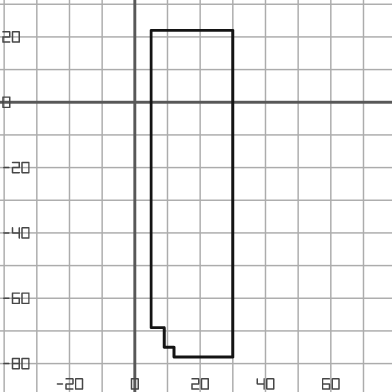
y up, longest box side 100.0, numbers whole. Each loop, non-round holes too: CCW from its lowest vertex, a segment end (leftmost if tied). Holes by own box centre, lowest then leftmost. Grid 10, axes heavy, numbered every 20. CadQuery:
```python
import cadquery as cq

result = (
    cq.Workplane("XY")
    .moveTo(12.0, -78.0)
    .lineTo(30.0, -78.0)
    .lineTo(30.0, 22.0)
    .lineTo(5.0, 22.0)
    .lineTo(5.0, -69.0)
    .lineTo(9.0, -69.0)
    .lineTo(9.0, -75.0)
    .lineTo(12.0, -75.0)
    .close()
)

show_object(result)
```